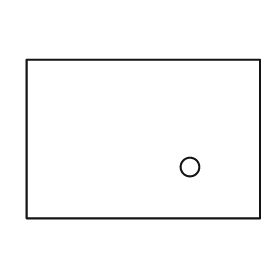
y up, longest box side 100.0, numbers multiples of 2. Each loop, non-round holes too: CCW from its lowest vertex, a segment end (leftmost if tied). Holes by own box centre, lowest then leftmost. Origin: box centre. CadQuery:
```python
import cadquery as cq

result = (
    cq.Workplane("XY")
    .moveTo(-50.0, -34.0)
    .lineTo(50.0, -34.0)
    .lineTo(50.0, 34.0)
    .lineTo(-50.0, 34.0)
    .close()
    .moveTo(20.0, -12.0)
    .circle(4.0)
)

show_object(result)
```